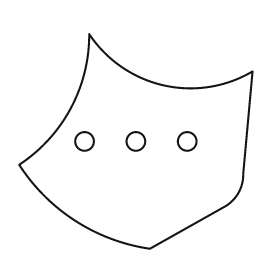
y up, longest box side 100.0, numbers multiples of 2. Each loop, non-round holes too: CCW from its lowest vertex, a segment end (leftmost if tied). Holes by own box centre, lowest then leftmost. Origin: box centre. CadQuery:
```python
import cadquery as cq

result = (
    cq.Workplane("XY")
    .moveTo(6.0, -46.0)
    .lineTo(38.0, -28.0)
    .threePointArc((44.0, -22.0), (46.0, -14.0))
    .lineTo(50.0, 30.0)
    .threePointArc((12.0, 24.0), (-20.0, 46.0))
    .threePointArc((-28.0, 14.0), (-50.0, -10.0))
    .threePointArc((-26.0, -34.0), (6.0, -46.0))
    .close()
    .moveTo(-22.0, 0.0)
    .circle(4.0)
    .moveTo(0.0, 0.0)
    .circle(4.0)
    .moveTo(22.0, 0.0)
    .circle(4.0)
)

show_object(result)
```